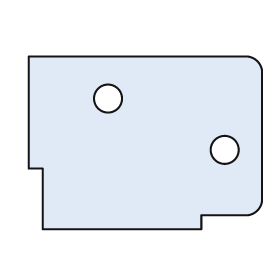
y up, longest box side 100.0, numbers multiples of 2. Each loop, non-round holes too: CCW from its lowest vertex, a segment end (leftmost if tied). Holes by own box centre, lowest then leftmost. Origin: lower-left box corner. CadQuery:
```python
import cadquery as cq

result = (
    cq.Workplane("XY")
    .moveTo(6.0, 0.0)
    .lineTo(74.0, 0.0)
    .lineTo(74.0, 6.0)
    .lineTo(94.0, 6.0)
    .threePointArc((98.0, 8.0), (100.0, 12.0))
    .lineTo(100.0, 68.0)
    .threePointArc((98.0, 72.0), (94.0, 74.0))
    .lineTo(0.0, 74.0)
    .lineTo(0.0, 26.0)
    .lineTo(6.0, 26.0)
    .close()
    .moveTo(84.0, 34.0)
    .circle(6.0)
    .moveTo(34.0, 56.0)
    .circle(6.0)
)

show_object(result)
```